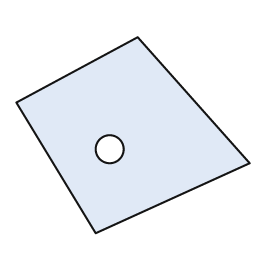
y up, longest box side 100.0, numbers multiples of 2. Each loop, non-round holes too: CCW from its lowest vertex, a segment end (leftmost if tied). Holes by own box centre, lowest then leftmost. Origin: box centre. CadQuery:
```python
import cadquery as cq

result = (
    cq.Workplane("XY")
    .moveTo(-16.0, -42.0)
    .lineTo(50.0, -12.0)
    .lineTo(2.0, 42.0)
    .lineTo(-50.0, 14.0)
    .close()
    .moveTo(-10.0, -6.0)
    .circle(6.0)
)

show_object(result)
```